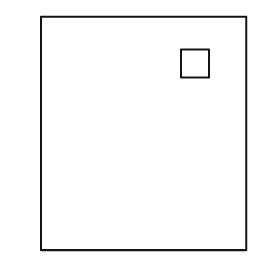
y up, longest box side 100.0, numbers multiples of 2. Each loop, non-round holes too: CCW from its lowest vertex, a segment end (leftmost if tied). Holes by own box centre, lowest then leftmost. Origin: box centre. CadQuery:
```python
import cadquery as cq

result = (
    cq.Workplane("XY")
    .moveTo(-44.0, -50.0)
    .lineTo(44.0, -50.0)
    .lineTo(44.0, 50.0)
    .lineTo(-44.0, 50.0)
    .close()
    .moveTo(16.0, 24.0)
    .lineTo(28.0, 24.0)
    .lineTo(28.0, 36.0)
    .lineTo(16.0, 36.0)
    .close()
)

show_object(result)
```